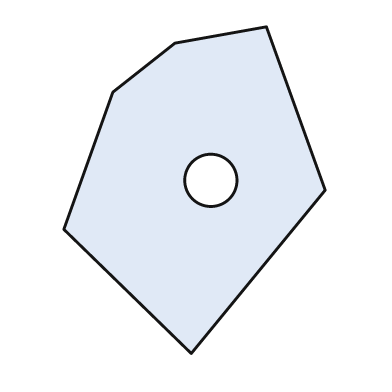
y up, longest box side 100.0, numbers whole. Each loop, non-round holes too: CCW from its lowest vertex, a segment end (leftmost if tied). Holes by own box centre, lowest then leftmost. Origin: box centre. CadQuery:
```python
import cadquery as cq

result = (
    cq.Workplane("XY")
    .moveTo(-1.0, -50.0)
    .lineTo(40.0, 0.0)
    .lineTo(22.0, 50.0)
    .lineTo(-6.0, 45.0)
    .lineTo(-25.0, 30.0)
    .lineTo(-40.0, -12.0)
    .close()
    .moveTo(5.0, 3.0)
    .circle(8.0)
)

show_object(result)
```